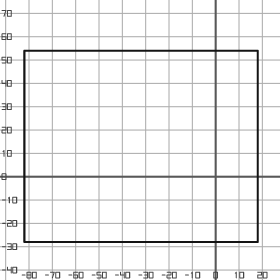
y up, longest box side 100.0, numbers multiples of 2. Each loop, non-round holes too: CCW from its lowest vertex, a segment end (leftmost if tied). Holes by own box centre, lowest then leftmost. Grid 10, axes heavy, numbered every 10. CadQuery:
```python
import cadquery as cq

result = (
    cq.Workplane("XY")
    .moveTo(-82.0, -28.0)
    .lineTo(18.0, -28.0)
    .lineTo(18.0, 54.0)
    .lineTo(-82.0, 54.0)
    .close()
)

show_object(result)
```